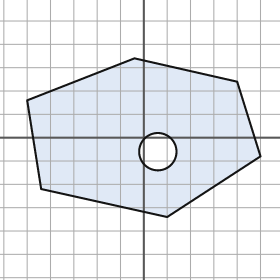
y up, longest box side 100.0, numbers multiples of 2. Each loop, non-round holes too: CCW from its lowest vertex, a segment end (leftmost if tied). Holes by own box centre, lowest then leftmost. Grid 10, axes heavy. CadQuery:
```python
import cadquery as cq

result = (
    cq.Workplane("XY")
    .moveTo(10.0, -34.0)
    .lineTo(50.0, -8.0)
    .lineTo(40.0, 24.0)
    .lineTo(-4.0, 34.0)
    .lineTo(-50.0, 16.0)
    .lineTo(-44.0, -22.0)
    .close()
    .moveTo(6.0, -6.0)
    .circle(8.0)
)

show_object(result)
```